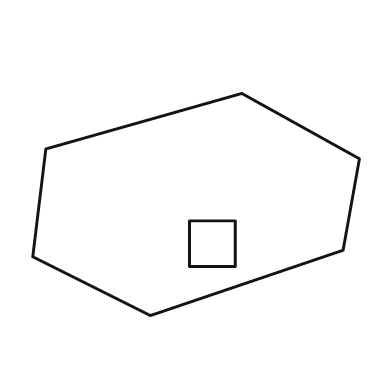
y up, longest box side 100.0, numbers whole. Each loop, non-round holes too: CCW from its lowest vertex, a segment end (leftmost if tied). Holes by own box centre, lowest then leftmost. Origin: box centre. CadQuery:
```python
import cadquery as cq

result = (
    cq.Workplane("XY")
    .moveTo(-14.0, -34.0)
    .lineTo(45.0, -14.0)
    .lineTo(50.0, 14.0)
    .lineTo(14.0, 34.0)
    .lineTo(-46.0, 17.0)
    .lineTo(-50.0, -16.0)
    .close()
    .moveTo(-2.0, -19.0)
    .lineTo(12.0, -19.0)
    .lineTo(12.0, -5.0)
    .lineTo(-2.0, -5.0)
    .close()
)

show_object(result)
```